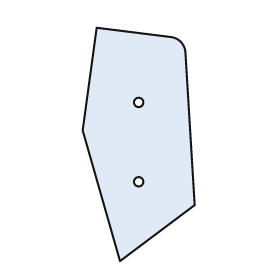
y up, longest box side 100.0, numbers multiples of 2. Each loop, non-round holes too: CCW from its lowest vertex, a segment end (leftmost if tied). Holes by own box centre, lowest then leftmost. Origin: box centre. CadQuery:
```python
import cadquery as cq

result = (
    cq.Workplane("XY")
    .moveTo(-8.0, -50.0)
    .lineTo(24.0, -26.0)
    .lineTo(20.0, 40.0)
    .threePointArc((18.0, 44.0), (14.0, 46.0))
    .lineTo(-18.0, 50.0)
    .lineTo(-24.0, 6.0)
    .close()
    .moveTo(0.0, -16.0)
    .circle(2.0)
    .moveTo(0.0, 18.0)
    .circle(2.0)
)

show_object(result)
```